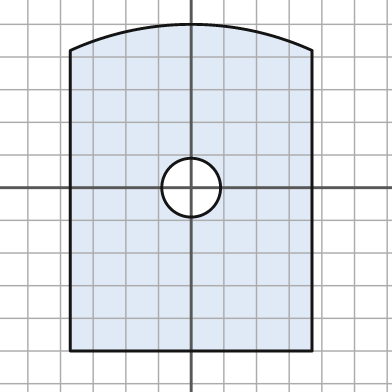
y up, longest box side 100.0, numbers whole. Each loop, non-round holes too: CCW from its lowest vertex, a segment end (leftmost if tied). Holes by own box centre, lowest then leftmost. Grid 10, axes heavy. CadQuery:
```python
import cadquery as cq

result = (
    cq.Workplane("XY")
    .moveTo(-37.0, -50.0)
    .lineTo(37.0, -50.0)
    .lineTo(37.0, 42.0)
    .threePointArc((0.0, 50.0), (-37.0, 42.0))
    .close()
    .moveTo(0.0, 0.0)
    .circle(9.0)
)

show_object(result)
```